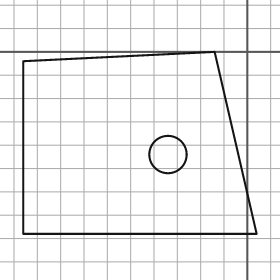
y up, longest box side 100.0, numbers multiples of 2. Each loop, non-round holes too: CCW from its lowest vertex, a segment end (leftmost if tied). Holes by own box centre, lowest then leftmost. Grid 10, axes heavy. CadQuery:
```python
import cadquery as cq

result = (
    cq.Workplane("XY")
    .moveTo(-96.0, -78.0)
    .lineTo(4.0, -78.0)
    .lineTo(-14.0, 0.0)
    .lineTo(-96.0, -4.0)
    .close()
    .moveTo(-34.0, -44.0)
    .circle(8.0)
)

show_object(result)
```